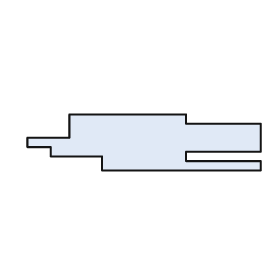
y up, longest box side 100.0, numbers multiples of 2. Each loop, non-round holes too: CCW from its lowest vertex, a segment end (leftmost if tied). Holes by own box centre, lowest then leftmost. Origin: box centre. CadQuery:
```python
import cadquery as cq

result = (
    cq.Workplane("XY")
    .moveTo(-18.0, -12.0)
    .lineTo(50.0, -12.0)
    .lineTo(50.0, -8.0)
    .lineTo(18.0, -8.0)
    .lineTo(18.0, -4.0)
    .lineTo(50.0, -4.0)
    .lineTo(50.0, 8.0)
    .lineTo(18.0, 8.0)
    .lineTo(18.0, 12.0)
    .lineTo(-32.0, 12.0)
    .lineTo(-32.0, 2.0)
    .lineTo(-50.0, 2.0)
    .lineTo(-50.0, -2.0)
    .lineTo(-40.0, -2.0)
    .lineTo(-40.0, -6.0)
    .lineTo(-18.0, -6.0)
    .close()
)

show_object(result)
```